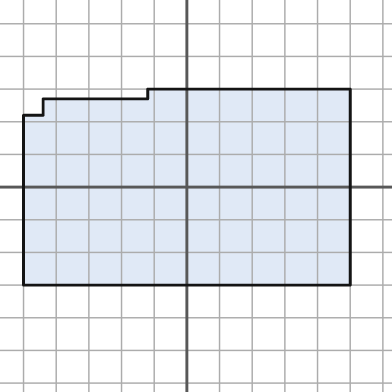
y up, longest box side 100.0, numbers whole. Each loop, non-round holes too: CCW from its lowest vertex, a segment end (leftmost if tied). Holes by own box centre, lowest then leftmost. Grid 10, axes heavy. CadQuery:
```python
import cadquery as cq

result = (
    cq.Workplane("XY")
    .moveTo(-50.0, -30.0)
    .lineTo(50.0, -30.0)
    .lineTo(50.0, 30.0)
    .lineTo(-12.0, 30.0)
    .lineTo(-12.0, 27.0)
    .lineTo(-44.0, 27.0)
    .lineTo(-44.0, 22.0)
    .lineTo(-50.0, 22.0)
    .close()
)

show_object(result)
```